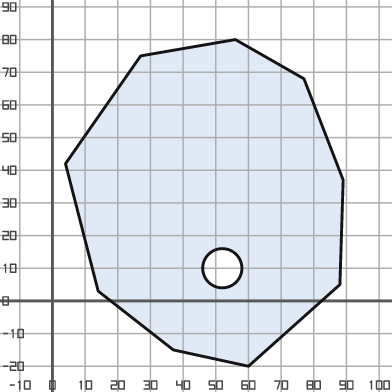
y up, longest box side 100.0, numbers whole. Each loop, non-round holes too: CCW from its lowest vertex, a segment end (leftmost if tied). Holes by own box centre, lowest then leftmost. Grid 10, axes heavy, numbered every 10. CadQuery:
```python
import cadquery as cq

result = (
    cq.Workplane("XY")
    .moveTo(60.0, -20.0)
    .lineTo(88.0, 5.0)
    .lineTo(89.0, 37.0)
    .lineTo(77.0, 68.0)
    .lineTo(56.0, 80.0)
    .lineTo(27.0, 75.0)
    .lineTo(4.0, 42.0)
    .lineTo(14.0, 3.0)
    .lineTo(37.0, -15.0)
    .close()
    .moveTo(52.0, 10.0)
    .circle(6.0)
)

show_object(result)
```